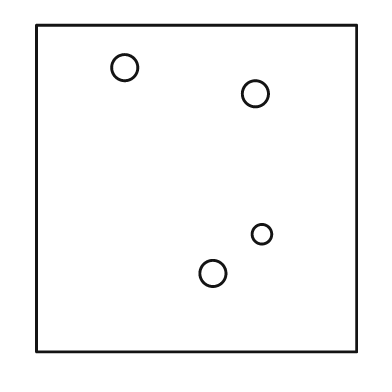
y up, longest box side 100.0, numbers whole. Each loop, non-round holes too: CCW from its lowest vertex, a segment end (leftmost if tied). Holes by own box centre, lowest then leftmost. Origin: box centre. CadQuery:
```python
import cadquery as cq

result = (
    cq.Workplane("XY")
    .moveTo(-49.0, -50.0)
    .lineTo(49.0, -50.0)
    .lineTo(49.0, 50.0)
    .lineTo(-49.0, 50.0)
    .close()
    .moveTo(5.0, -26.0)
    .circle(4.0)
    .moveTo(20.0, -14.0)
    .circle(3.0)
    .moveTo(18.0, 29.0)
    .circle(4.0)
    .moveTo(-22.0, 37.0)
    .circle(4.0)
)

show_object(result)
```